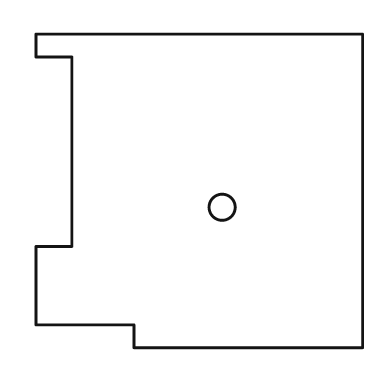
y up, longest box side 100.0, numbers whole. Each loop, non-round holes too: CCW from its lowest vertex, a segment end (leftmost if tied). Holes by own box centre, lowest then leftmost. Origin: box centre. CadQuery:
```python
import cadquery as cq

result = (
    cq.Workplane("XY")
    .moveTo(-20.0, -48.0)
    .lineTo(50.0, -48.0)
    .lineTo(50.0, 48.0)
    .lineTo(-50.0, 48.0)
    .lineTo(-50.0, 41.0)
    .lineTo(-39.0, 41.0)
    .lineTo(-39.0, -17.0)
    .lineTo(-50.0, -17.0)
    .lineTo(-50.0, -41.0)
    .lineTo(-20.0, -41.0)
    .close()
    .moveTo(7.0, -5.0)
    .circle(4.0)
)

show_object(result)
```